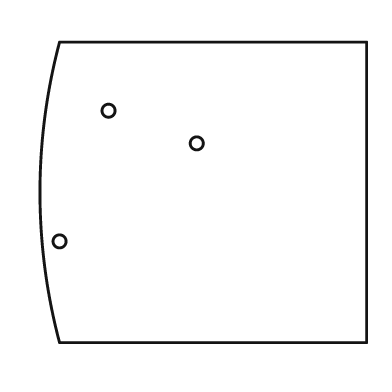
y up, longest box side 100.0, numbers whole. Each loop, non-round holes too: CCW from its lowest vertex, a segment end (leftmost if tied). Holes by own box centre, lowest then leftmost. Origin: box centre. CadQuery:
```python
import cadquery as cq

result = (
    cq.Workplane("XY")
    .moveTo(-44.0, -46.0)
    .lineTo(50.0, -46.0)
    .lineTo(50.0, 46.0)
    .lineTo(-44.0, 46.0)
    .threePointArc((-50.0, 0.0), (-44.0, -46.0))
    .close()
    .moveTo(-44.0, -15.0)
    .circle(2.0)
    .moveTo(-2.0, 15.0)
    .circle(2.0)
    .moveTo(-29.0, 25.0)
    .circle(2.0)
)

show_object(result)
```